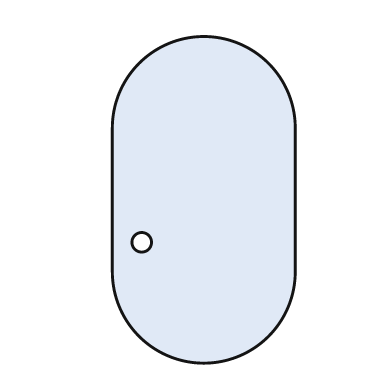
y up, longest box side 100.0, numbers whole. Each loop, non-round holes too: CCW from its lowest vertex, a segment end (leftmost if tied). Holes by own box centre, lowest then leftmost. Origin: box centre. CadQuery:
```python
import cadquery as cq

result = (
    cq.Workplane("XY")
    .moveTo(-28.0, -22.0)
    .threePointArc((0.0, -50.0), (28.0, -22.0))
    .lineTo(28.0, 22.0)
    .threePointArc((0.0, 50.0), (-28.0, 22.0))
    .close()
    .moveTo(-19.0, -13.0)
    .circle(3.0)
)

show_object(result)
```